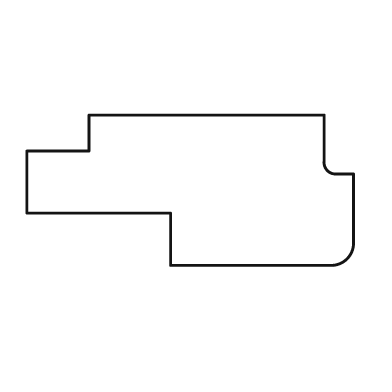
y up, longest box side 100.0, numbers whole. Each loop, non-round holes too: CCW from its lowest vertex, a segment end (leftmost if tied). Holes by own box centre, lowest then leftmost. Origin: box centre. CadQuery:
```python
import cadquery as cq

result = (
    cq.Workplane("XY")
    .moveTo(-6.0, -23.0)
    .lineTo(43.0, -23.0)
    .threePointArc((48.0, -21.0), (50.0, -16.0))
    .lineTo(50.0, 5.0)
    .lineTo(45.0, 5.0)
    .threePointArc((42.0, 6.0), (41.0, 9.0))
    .lineTo(41.0, 23.0)
    .lineTo(-31.0, 23.0)
    .lineTo(-31.0, 12.0)
    .lineTo(-50.0, 12.0)
    .lineTo(-50.0, -7.0)
    .lineTo(-6.0, -7.0)
    .close()
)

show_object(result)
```